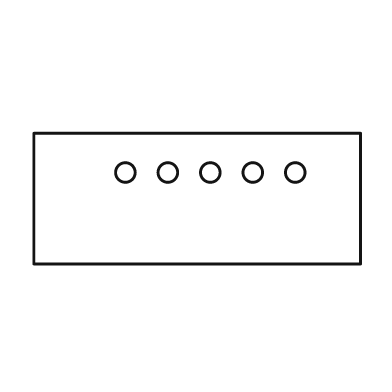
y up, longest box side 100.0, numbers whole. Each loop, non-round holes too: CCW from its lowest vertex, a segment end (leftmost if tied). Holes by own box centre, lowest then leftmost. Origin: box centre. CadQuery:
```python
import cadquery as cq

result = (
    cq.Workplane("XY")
    .moveTo(-50.0, -20.0)
    .lineTo(50.0, -20.0)
    .lineTo(50.0, 20.0)
    .lineTo(-50.0, 20.0)
    .close()
    .moveTo(-22.0, 8.0)
    .circle(3.0)
    .moveTo(-9.0, 8.0)
    .circle(3.0)
    .moveTo(4.0, 8.0)
    .circle(3.0)
    .moveTo(17.0, 8.0)
    .circle(3.0)
    .moveTo(30.0, 8.0)
    .circle(3.0)
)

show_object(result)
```